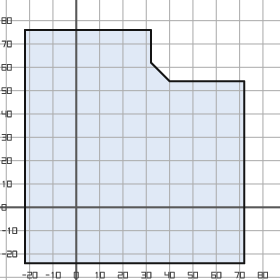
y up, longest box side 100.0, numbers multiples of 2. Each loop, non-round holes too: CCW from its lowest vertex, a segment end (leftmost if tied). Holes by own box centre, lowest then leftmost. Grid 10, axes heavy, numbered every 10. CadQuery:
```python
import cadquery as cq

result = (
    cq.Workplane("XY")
    .moveTo(-22.0, -24.0)
    .lineTo(72.0, -24.0)
    .lineTo(72.0, 54.0)
    .lineTo(40.0, 54.0)
    .lineTo(32.0, 62.0)
    .lineTo(32.0, 76.0)
    .lineTo(-22.0, 76.0)
    .close()
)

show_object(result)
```